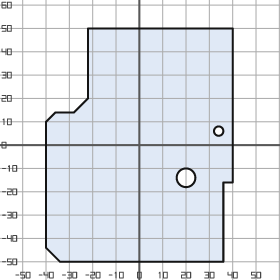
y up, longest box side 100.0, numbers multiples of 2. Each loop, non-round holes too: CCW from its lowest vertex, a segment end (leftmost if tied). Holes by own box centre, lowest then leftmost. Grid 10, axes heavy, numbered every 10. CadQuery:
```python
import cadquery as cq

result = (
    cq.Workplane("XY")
    .moveTo(-34.0, -50.0)
    .lineTo(36.0, -50.0)
    .lineTo(36.0, -16.0)
    .lineTo(40.0, -16.0)
    .lineTo(40.0, 50.0)
    .lineTo(-22.0, 50.0)
    .lineTo(-22.0, 20.0)
    .lineTo(-28.0, 14.0)
    .lineTo(-36.0, 14.0)
    .lineTo(-40.0, 10.0)
    .lineTo(-40.0, -44.0)
    .close()
    .moveTo(20.0, -14.0)
    .circle(4.0)
    .moveTo(34.0, 6.0)
    .circle(2.0)
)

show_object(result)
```